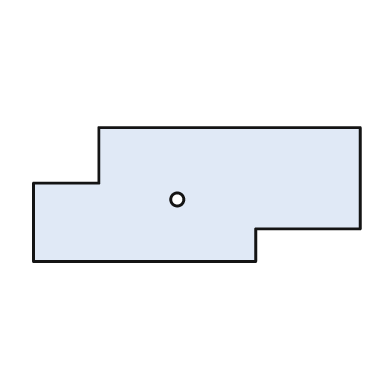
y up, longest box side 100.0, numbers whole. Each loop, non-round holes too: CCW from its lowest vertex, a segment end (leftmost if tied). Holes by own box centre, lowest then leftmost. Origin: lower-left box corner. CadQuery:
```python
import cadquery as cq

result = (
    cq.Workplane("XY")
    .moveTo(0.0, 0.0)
    .lineTo(68.0, 0.0)
    .lineTo(68.0, 10.0)
    .lineTo(100.0, 10.0)
    .lineTo(100.0, 41.0)
    .lineTo(20.0, 41.0)
    .lineTo(20.0, 24.0)
    .lineTo(0.0, 24.0)
    .close()
    .moveTo(44.0, 19.0)
    .circle(2.0)
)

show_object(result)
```